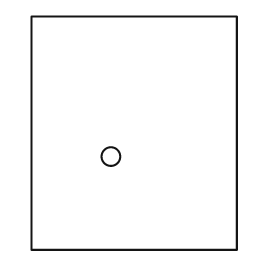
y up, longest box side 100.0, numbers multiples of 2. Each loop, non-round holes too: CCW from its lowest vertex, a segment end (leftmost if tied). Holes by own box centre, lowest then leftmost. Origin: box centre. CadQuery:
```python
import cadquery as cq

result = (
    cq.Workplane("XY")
    .moveTo(-44.0, -50.0)
    .lineTo(44.0, -50.0)
    .lineTo(44.0, 50.0)
    .lineTo(-44.0, 50.0)
    .close()
    .moveTo(-10.0, -10.0)
    .circle(4.0)
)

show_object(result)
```